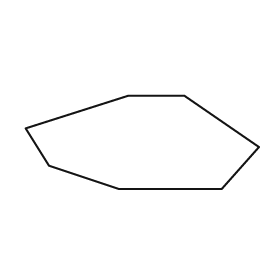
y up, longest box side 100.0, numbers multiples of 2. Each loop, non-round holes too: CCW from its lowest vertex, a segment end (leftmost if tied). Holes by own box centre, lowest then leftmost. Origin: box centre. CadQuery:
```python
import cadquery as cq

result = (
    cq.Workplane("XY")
    .moveTo(-10.0, -20.0)
    .lineTo(34.0, -20.0)
    .lineTo(50.0, -2.0)
    .lineTo(18.0, 20.0)
    .lineTo(-6.0, 20.0)
    .lineTo(-50.0, 6.0)
    .lineTo(-40.0, -10.0)
    .close()
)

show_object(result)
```